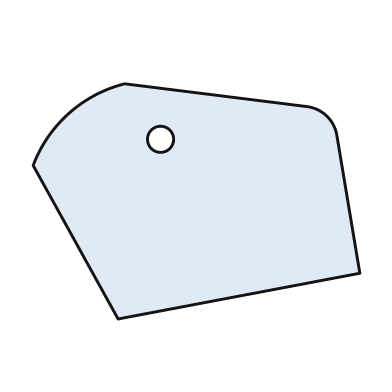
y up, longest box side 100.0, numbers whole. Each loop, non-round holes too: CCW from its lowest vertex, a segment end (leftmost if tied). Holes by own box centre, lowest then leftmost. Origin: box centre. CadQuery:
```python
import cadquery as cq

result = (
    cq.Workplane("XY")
    .moveTo(-24.0, -36.0)
    .lineTo(50.0, -22.0)
    .lineTo(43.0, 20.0)
    .threePointArc((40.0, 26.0), (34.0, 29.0))
    .lineTo(-22.0, 36.0)
    .threePointArc((-39.0, 27.0), (-50.0, 11.0))
    .close()
    .moveTo(-11.0, 19.0)
    .circle(4.0)
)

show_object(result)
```